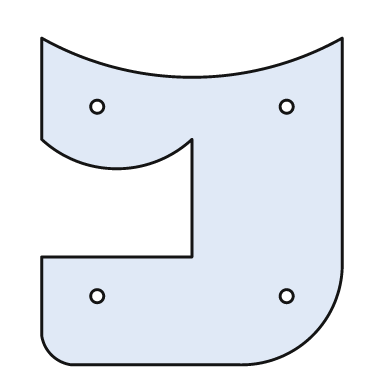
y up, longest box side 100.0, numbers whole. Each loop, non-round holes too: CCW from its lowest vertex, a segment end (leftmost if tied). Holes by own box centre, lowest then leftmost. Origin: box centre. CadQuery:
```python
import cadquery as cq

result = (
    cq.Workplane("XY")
    .moveTo(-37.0, -50.0)
    .lineTo(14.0, -50.0)
    .threePointArc((37.0, -41.0), (46.0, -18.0))
    .lineTo(46.0, 50.0)
    .threePointArc((0.0, 38.0), (-46.0, 50.0))
    .lineTo(-46.0, 19.0)
    .threePointArc((-23.0, 10.0), (0.0, 19.0))
    .lineTo(0.0, -17.0)
    .lineTo(-46.0, -17.0)
    .lineTo(-46.0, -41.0)
    .threePointArc((-43.0, -47.0), (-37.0, -50.0))
    .close()
    .moveTo(-29.0, -29.0)
    .circle(2.0)
    .moveTo(29.0, -29.0)
    .circle(2.0)
    .moveTo(-29.0, 29.0)
    .circle(2.0)
    .moveTo(29.0, 29.0)
    .circle(2.0)
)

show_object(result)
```